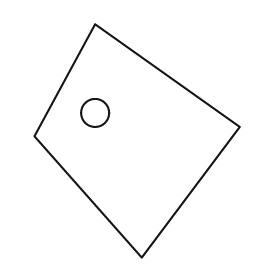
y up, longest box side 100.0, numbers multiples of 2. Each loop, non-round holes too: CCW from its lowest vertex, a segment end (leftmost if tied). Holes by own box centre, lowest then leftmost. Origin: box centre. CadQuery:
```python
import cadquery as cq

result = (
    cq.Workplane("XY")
    .moveTo(2.0, -50.0)
    .lineTo(44.0, 6.0)
    .lineTo(-18.0, 50.0)
    .lineTo(-44.0, 2.0)
    .close()
    .moveTo(-18.0, 12.0)
    .circle(6.0)
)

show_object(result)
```